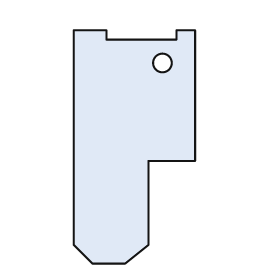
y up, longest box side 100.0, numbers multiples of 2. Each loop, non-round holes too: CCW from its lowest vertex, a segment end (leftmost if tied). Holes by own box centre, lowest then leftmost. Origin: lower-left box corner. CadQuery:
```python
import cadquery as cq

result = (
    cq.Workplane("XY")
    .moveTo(8.0, 0.0)
    .lineTo(22.0, 0.0)
    .lineTo(32.0, 8.0)
    .lineTo(32.0, 44.0)
    .lineTo(52.0, 44.0)
    .lineTo(52.0, 100.0)
    .lineTo(44.0, 100.0)
    .lineTo(44.0, 96.0)
    .lineTo(14.0, 96.0)
    .lineTo(14.0, 100.0)
    .lineTo(0.0, 100.0)
    .lineTo(0.0, 8.0)
    .close()
    .moveTo(38.0, 86.0)
    .circle(4.0)
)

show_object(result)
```